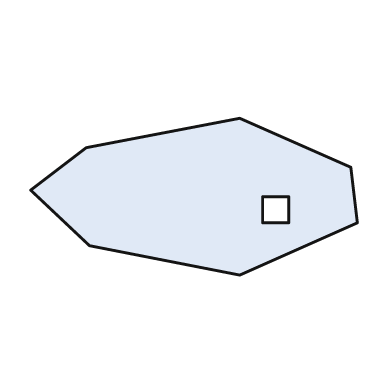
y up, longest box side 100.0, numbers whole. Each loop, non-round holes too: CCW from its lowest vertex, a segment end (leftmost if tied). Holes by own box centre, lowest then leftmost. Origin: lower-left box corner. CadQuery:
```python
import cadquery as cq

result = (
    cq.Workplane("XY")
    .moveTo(64.0, 0.0)
    .lineTo(100.0, 16.0)
    .lineTo(98.0, 33.0)
    .lineTo(64.0, 48.0)
    .lineTo(17.0, 39.0)
    .lineTo(0.0, 26.0)
    .lineTo(18.0, 9.0)
    .close()
    .moveTo(71.0, 16.0)
    .lineTo(79.0, 16.0)
    .lineTo(79.0, 24.0)
    .lineTo(71.0, 24.0)
    .close()
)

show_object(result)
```